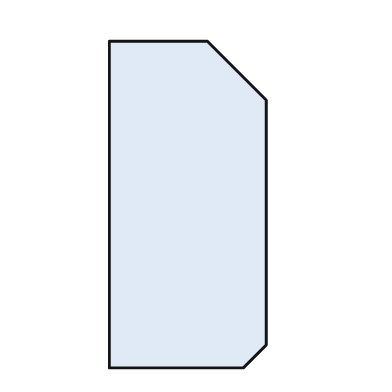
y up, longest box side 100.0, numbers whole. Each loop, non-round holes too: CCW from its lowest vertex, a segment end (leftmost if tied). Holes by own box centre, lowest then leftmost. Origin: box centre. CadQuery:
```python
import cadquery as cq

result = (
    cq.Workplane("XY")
    .moveTo(-24.0, -50.0)
    .lineTo(17.0, -50.0)
    .lineTo(24.0, -43.0)
    .lineTo(24.0, 32.0)
    .lineTo(6.0, 50.0)
    .lineTo(-24.0, 50.0)
    .close()
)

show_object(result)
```